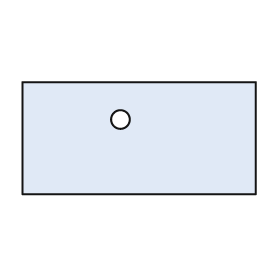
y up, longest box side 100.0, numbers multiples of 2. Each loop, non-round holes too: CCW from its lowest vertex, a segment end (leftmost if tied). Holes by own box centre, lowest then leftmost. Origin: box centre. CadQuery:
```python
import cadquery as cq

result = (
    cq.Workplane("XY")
    .moveTo(-50.0, -24.0)
    .lineTo(50.0, -24.0)
    .lineTo(50.0, 24.0)
    .lineTo(-50.0, 24.0)
    .close()
    .moveTo(-8.0, 8.0)
    .circle(4.0)
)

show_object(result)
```